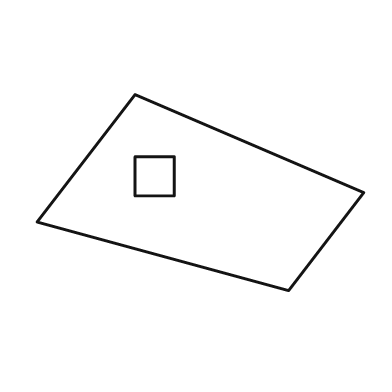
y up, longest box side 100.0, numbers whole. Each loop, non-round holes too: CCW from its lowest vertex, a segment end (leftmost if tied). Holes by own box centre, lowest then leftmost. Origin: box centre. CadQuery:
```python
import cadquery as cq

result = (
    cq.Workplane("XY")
    .moveTo(27.0, -30.0)
    .lineTo(50.0, 0.0)
    .lineTo(-20.0, 30.0)
    .lineTo(-50.0, -9.0)
    .close()
    .moveTo(-20.0, -1.0)
    .lineTo(-8.0, -1.0)
    .lineTo(-8.0, 11.0)
    .lineTo(-20.0, 11.0)
    .close()
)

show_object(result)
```